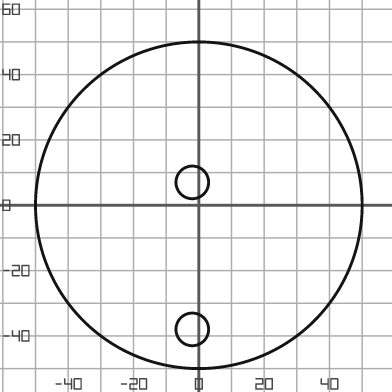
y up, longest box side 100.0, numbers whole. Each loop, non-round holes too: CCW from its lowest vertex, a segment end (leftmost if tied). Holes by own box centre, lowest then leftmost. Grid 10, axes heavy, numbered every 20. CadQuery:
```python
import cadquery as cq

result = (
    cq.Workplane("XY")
    .moveTo(0.0, 0.0)
    .circle(50.0)
    .moveTo(-2.0, -38.0)
    .circle(5.0)
    .moveTo(-2.0, 7.0)
    .circle(5.0)
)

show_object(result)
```